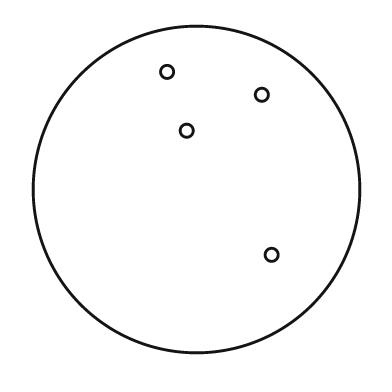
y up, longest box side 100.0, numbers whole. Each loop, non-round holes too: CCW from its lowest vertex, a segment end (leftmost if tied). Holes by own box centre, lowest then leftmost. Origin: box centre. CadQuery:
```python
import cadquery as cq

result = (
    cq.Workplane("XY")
    .moveTo(0.0, 0.0)
    .circle(50.0)
    .moveTo(23.0, -20.0)
    .circle(2.0)
    .moveTo(-3.0, 18.0)
    .circle(2.0)
    .moveTo(20.0, 29.0)
    .circle(2.0)
    .moveTo(-9.0, 36.0)
    .circle(2.0)
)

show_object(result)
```